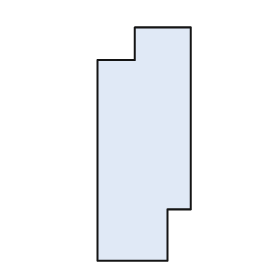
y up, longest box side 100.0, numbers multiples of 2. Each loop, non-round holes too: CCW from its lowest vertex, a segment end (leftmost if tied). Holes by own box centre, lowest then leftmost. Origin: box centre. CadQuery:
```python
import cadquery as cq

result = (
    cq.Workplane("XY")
    .moveTo(-20.0, -50.0)
    .lineTo(10.0, -50.0)
    .lineTo(10.0, -28.0)
    .lineTo(20.0, -28.0)
    .lineTo(20.0, 50.0)
    .lineTo(-4.0, 50.0)
    .lineTo(-4.0, 36.0)
    .lineTo(-20.0, 36.0)
    .close()
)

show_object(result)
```